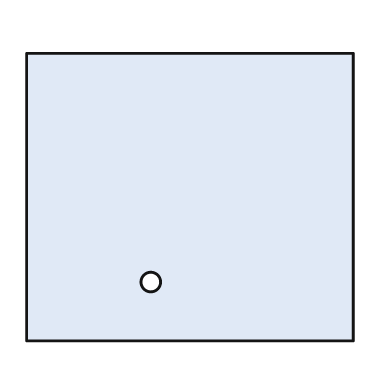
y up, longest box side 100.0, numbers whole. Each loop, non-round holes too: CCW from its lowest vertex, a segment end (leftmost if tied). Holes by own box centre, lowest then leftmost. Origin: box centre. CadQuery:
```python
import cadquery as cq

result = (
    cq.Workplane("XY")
    .moveTo(-50.0, -44.0)
    .lineTo(50.0, -44.0)
    .lineTo(50.0, 44.0)
    .lineTo(-50.0, 44.0)
    .close()
    .moveTo(-12.0, -26.0)
    .circle(3.0)
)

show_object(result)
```